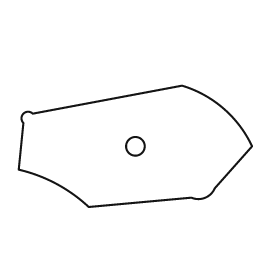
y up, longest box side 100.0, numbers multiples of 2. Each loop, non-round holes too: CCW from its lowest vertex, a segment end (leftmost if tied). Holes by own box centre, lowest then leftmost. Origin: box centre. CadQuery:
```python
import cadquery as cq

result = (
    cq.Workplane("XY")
    .moveTo(-20.0, -26.0)
    .lineTo(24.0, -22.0)
    .threePointArc((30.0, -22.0), (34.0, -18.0))
    .lineTo(50.0, 0.0)
    .threePointArc((38.0, 16.0), (20.0, 26.0))
    .lineTo(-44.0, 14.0)
    .threePointArc((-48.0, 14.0), (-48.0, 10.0))
    .lineTo(-50.0, -10.0)
    .threePointArc((-34.0, -16.0), (-20.0, -26.0))
    .close()
    .moveTo(0.0, 0.0)
    .circle(4.0)
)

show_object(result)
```